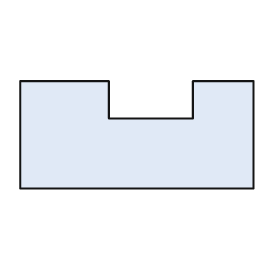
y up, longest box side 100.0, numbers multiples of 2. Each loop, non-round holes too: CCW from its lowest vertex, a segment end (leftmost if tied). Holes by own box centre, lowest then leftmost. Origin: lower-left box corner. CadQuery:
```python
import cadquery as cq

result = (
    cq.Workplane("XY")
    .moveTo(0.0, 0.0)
    .lineTo(100.0, 0.0)
    .lineTo(100.0, 46.0)
    .lineTo(74.0, 46.0)
    .lineTo(74.0, 30.0)
    .lineTo(38.0, 30.0)
    .lineTo(38.0, 46.0)
    .lineTo(0.0, 46.0)
    .close()
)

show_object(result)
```